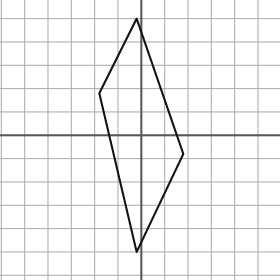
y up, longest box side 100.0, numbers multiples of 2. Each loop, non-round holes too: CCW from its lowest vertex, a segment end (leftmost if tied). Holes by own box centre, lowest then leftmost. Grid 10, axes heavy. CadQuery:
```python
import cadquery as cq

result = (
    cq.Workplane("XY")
    .moveTo(-2.0, -50.0)
    .lineTo(18.0, -8.0)
    .lineTo(-2.0, 50.0)
    .lineTo(-18.0, 18.0)
    .close()
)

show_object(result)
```